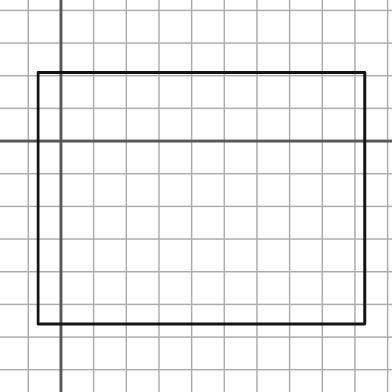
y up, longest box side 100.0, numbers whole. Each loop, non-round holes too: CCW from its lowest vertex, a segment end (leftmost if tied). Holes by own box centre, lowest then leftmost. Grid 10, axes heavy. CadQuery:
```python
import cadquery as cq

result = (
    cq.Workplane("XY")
    .moveTo(-7.0, -56.0)
    .lineTo(93.0, -56.0)
    .lineTo(93.0, 21.0)
    .lineTo(-7.0, 21.0)
    .close()
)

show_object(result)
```